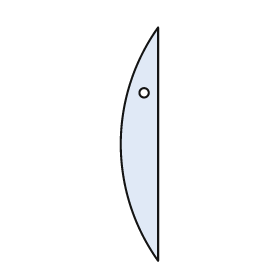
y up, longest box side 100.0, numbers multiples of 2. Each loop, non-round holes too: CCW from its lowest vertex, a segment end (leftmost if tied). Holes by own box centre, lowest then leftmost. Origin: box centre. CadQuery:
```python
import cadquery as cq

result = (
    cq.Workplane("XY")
    .moveTo(8.0, -50.0)
    .lineTo(8.0, 50.0)
    .threePointArc((-8.0, 0.0), (8.0, -50.0))
    .close()
    .moveTo(2.0, 22.0)
    .circle(2.0)
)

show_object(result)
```